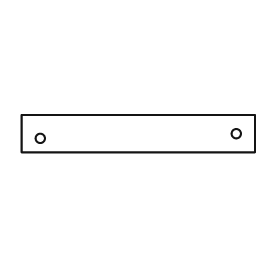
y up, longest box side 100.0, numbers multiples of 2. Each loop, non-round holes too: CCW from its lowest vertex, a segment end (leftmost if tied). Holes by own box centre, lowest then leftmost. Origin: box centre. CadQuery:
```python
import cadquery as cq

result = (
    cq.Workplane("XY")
    .moveTo(-50.0, -8.0)
    .lineTo(50.0, -8.0)
    .lineTo(50.0, 8.0)
    .lineTo(-50.0, 8.0)
    .close()
    .moveTo(-42.0, -2.0)
    .circle(2.0)
    .moveTo(42.0, 0.0)
    .circle(2.0)
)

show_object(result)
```